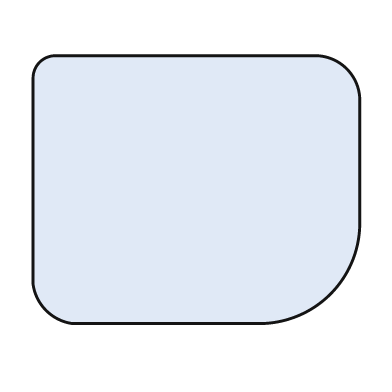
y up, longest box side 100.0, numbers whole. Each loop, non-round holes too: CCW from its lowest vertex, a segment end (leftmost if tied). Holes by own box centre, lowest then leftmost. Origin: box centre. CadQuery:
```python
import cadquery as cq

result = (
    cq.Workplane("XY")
    .moveTo(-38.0, -41.0)
    .lineTo(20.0, -41.0)
    .threePointArc((41.0, -32.0), (50.0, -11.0))
    .lineTo(50.0, 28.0)
    .threePointArc((46.0, 37.0), (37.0, 41.0))
    .lineTo(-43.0, 41.0)
    .threePointArc((-48.0, 39.0), (-50.0, 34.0))
    .lineTo(-50.0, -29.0)
    .threePointArc((-46.0, -37.0), (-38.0, -41.0))
    .close()
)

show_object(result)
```